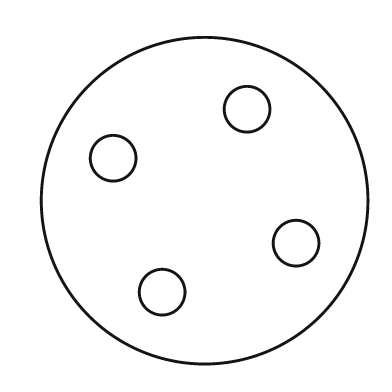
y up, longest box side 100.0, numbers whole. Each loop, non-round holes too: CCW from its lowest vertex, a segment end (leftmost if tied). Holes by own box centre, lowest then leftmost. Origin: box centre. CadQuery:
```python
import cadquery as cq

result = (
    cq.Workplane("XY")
    .moveTo(0.0, 0.0)
    .circle(50.0)
    .moveTo(-13.0, -28.0)
    .circle(7.0)
    .moveTo(28.0, -13.0)
    .circle(7.0)
    .moveTo(-28.0, 13.0)
    .circle(7.0)
    .moveTo(13.0, 28.0)
    .circle(7.0)
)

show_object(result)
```